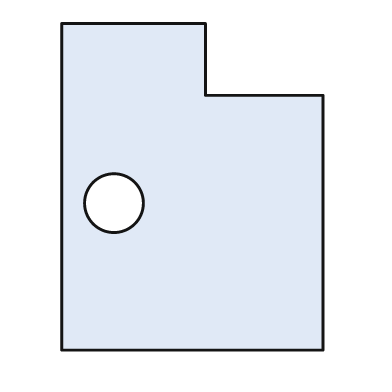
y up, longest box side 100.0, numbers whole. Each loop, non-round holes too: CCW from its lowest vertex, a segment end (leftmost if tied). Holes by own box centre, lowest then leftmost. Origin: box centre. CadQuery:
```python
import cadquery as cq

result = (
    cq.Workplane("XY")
    .moveTo(-40.0, -50.0)
    .lineTo(40.0, -50.0)
    .lineTo(40.0, 28.0)
    .lineTo(4.0, 28.0)
    .lineTo(4.0, 50.0)
    .lineTo(-40.0, 50.0)
    .close()
    .moveTo(-24.0, -5.0)
    .circle(9.0)
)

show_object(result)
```